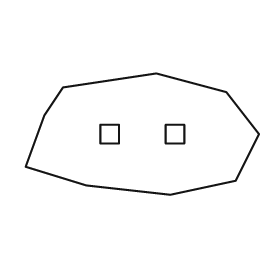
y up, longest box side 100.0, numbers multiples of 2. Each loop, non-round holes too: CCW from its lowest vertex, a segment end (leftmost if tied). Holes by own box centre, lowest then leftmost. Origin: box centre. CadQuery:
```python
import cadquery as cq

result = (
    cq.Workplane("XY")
    .moveTo(12.0, -26.0)
    .lineTo(40.0, -20.0)
    .lineTo(50.0, 0.0)
    .lineTo(36.0, 18.0)
    .lineTo(6.0, 26.0)
    .lineTo(-34.0, 20.0)
    .lineTo(-42.0, 8.0)
    .lineTo(-50.0, -14.0)
    .lineTo(-24.0, -22.0)
    .close()
    .moveTo(-18.0, -4.0)
    .lineTo(-10.0, -4.0)
    .lineTo(-10.0, 4.0)
    .lineTo(-18.0, 4.0)
    .close()
    .moveTo(10.0, -4.0)
    .lineTo(18.0, -4.0)
    .lineTo(18.0, 4.0)
    .lineTo(10.0, 4.0)
    .close()
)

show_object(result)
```